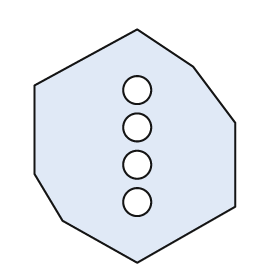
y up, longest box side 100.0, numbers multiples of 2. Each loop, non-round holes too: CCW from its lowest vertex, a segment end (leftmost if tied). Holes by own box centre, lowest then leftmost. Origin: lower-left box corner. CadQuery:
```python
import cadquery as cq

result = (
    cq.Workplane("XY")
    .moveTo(44.0, 0.0)
    .lineTo(86.0, 24.0)
    .lineTo(86.0, 60.0)
    .lineTo(68.0, 84.0)
    .lineTo(44.0, 100.0)
    .lineTo(0.0, 76.0)
    .lineTo(0.0, 38.0)
    .lineTo(12.0, 18.0)
    .close()
    .moveTo(44.0, 26.0)
    .circle(6.0)
    .moveTo(44.0, 42.0)
    .circle(6.0)
    .moveTo(44.0, 58.0)
    .circle(6.0)
    .moveTo(44.0, 74.0)
    .circle(6.0)
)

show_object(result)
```